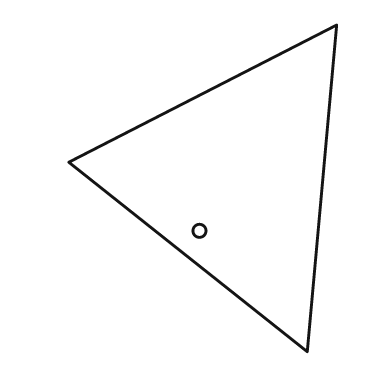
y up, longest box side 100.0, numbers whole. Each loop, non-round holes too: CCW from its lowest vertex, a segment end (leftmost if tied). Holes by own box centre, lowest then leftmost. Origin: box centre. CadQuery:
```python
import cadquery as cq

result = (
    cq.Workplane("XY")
    .moveTo(32.0, -50.0)
    .lineTo(41.0, 50.0)
    .lineTo(-41.0, 8.0)
    .close()
    .moveTo(-1.0, -13.0)
    .circle(2.0)
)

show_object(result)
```